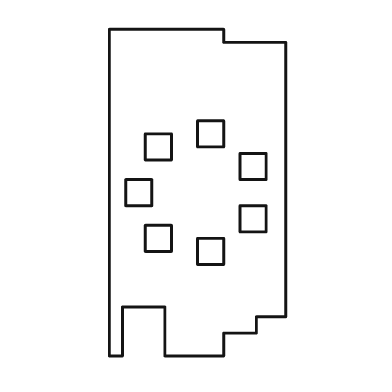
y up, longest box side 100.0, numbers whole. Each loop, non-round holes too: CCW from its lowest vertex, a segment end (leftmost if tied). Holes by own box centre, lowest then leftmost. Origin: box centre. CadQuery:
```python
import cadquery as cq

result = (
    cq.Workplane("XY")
    .moveTo(-27.0, -50.0)
    .lineTo(-23.0, -50.0)
    .lineTo(-23.0, -35.0)
    .lineTo(-10.0, -35.0)
    .lineTo(-10.0, -50.0)
    .lineTo(8.0, -50.0)
    .lineTo(8.0, -43.0)
    .lineTo(18.0, -43.0)
    .lineTo(18.0, -38.0)
    .lineTo(27.0, -38.0)
    .lineTo(27.0, 46.0)
    .lineTo(8.0, 46.0)
    .lineTo(8.0, 50.0)
    .lineTo(-27.0, 50.0)
    .close()
    .moveTo(0.0, -22.0)
    .lineTo(8.0, -22.0)
    .lineTo(8.0, -14.0)
    .lineTo(0.0, -14.0)
    .close()
    .moveTo(-16.0, -18.0)
    .lineTo(-8.0, -18.0)
    .lineTo(-8.0, -10.0)
    .lineTo(-16.0, -10.0)
    .close()
    .moveTo(13.0, -12.0)
    .lineTo(21.0, -12.0)
    .lineTo(21.0, -4.0)
    .lineTo(13.0, -4.0)
    .close()
    .moveTo(-22.0, -4.0)
    .lineTo(-14.0, -4.0)
    .lineTo(-14.0, 4.0)
    .lineTo(-22.0, 4.0)
    .close()
    .moveTo(13.0, 4.0)
    .lineTo(21.0, 4.0)
    .lineTo(21.0, 12.0)
    .lineTo(13.0, 12.0)
    .close()
    .moveTo(-16.0, 10.0)
    .lineTo(-8.0, 10.0)
    .lineTo(-8.0, 18.0)
    .lineTo(-16.0, 18.0)
    .close()
    .moveTo(0.0, 14.0)
    .lineTo(8.0, 14.0)
    .lineTo(8.0, 22.0)
    .lineTo(0.0, 22.0)
    .close()
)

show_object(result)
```